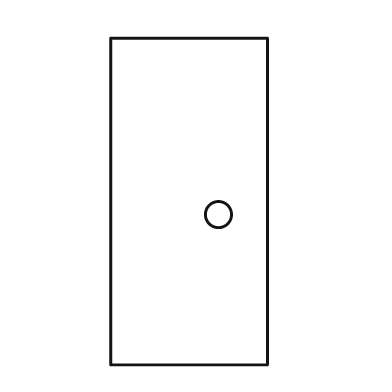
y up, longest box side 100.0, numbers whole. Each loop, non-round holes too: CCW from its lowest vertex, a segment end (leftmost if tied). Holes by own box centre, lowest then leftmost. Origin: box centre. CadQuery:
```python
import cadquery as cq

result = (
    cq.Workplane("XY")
    .moveTo(-24.0, -50.0)
    .lineTo(24.0, -50.0)
    .lineTo(24.0, 50.0)
    .lineTo(-24.0, 50.0)
    .close()
    .moveTo(9.0, -4.0)
    .circle(4.0)
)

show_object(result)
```